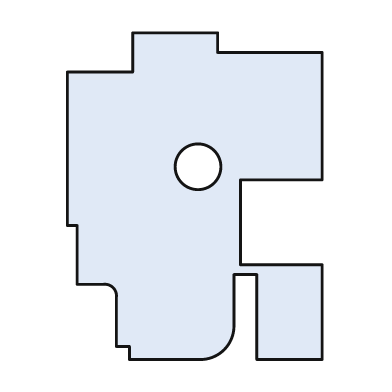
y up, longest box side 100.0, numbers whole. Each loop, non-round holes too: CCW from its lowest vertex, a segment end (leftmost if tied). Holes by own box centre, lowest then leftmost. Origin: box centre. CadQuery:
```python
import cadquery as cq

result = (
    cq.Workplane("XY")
    .moveTo(-20.0, -50.0)
    .lineTo(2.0, -50.0)
    .threePointArc((9.0, -47.0), (12.0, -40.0))
    .lineTo(12.0, -24.0)
    .lineTo(19.0, -24.0)
    .lineTo(19.0, -50.0)
    .lineTo(39.0, -50.0)
    .lineTo(39.0, -21.0)
    .lineTo(14.0, -21.0)
    .lineTo(14.0, 5.0)
    .lineTo(39.0, 5.0)
    .lineTo(39.0, 44.0)
    .lineTo(7.0, 44.0)
    .lineTo(7.0, 50.0)
    .lineTo(-19.0, 50.0)
    .lineTo(-19.0, 38.0)
    .lineTo(-39.0, 38.0)
    .lineTo(-39.0, -9.0)
    .lineTo(-36.0, -9.0)
    .lineTo(-36.0, -27.0)
    .lineTo(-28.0, -27.0)
    .threePointArc((-25.0, -28.0), (-24.0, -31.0))
    .lineTo(-24.0, -46.0)
    .lineTo(-20.0, -46.0)
    .close()
    .moveTo(1.0, 9.0)
    .circle(7.0)
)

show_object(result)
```